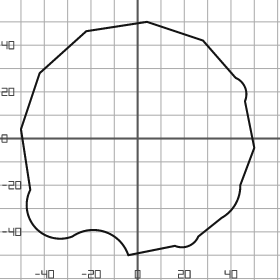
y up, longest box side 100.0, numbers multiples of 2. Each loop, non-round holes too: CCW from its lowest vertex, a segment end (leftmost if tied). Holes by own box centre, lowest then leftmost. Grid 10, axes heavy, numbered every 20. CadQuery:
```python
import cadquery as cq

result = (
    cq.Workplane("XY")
    .moveTo(-4.0, -50.0)
    .lineTo(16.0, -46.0)
    .threePointArc((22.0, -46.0), (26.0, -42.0))
    .lineTo(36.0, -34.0)
    .threePointArc((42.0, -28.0), (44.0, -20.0))
    .lineTo(50.0, -4.0)
    .lineTo(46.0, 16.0)
    .threePointArc((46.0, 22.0), (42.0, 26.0))
    .lineTo(28.0, 42.0)
    .lineTo(4.0, 50.0)
    .lineTo(-22.0, 46.0)
    .lineTo(-42.0, 28.0)
    .lineTo(-50.0, 4.0)
    .lineTo(-46.0, -22.0)
    .threePointArc((-44.0, -38.0), (-28.0, -42.0))
    .threePointArc((-14.0, -40.0), (-4.0, -50.0))
    .close()
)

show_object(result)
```